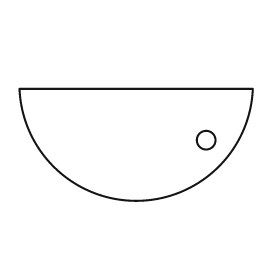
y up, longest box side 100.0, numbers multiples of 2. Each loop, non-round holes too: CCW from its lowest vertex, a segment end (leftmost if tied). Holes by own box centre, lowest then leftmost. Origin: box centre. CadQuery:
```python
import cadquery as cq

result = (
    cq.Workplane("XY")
    .moveTo(-50.0, 24.0)
    .threePointArc((0.0, -24.0), (50.0, 24.0))
    .close()
    .moveTo(30.0, 2.0)
    .circle(4.0)
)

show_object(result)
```